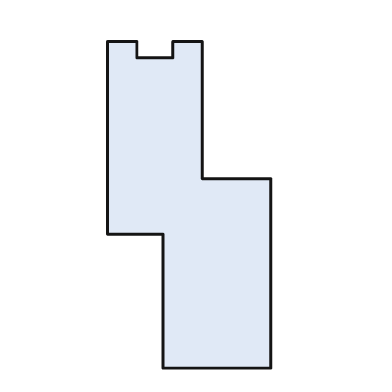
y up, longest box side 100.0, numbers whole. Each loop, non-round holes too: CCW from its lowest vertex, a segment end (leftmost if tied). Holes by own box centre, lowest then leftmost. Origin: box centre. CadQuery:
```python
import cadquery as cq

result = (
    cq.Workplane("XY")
    .moveTo(-8.0, -50.0)
    .lineTo(25.0, -50.0)
    .lineTo(25.0, 8.0)
    .lineTo(4.0, 8.0)
    .lineTo(4.0, 50.0)
    .lineTo(-5.0, 50.0)
    .lineTo(-5.0, 45.0)
    .lineTo(-16.0, 45.0)
    .lineTo(-16.0, 50.0)
    .lineTo(-25.0, 50.0)
    .lineTo(-25.0, -9.0)
    .lineTo(-8.0, -9.0)
    .close()
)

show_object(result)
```